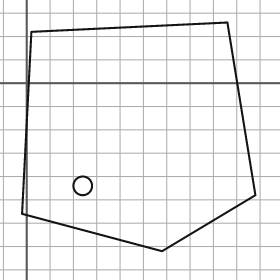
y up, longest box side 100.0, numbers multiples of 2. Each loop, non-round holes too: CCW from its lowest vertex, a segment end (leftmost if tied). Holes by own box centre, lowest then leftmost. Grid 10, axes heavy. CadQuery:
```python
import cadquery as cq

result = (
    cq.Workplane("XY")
    .moveTo(58.0, -72.0)
    .lineTo(98.0, -48.0)
    .lineTo(86.0, 26.0)
    .lineTo(2.0, 22.0)
    .lineTo(-2.0, -56.0)
    .close()
    .moveTo(24.0, -44.0)
    .circle(4.0)
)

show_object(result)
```